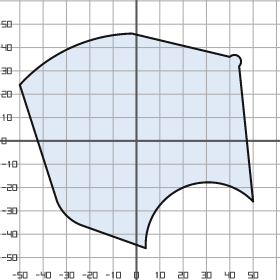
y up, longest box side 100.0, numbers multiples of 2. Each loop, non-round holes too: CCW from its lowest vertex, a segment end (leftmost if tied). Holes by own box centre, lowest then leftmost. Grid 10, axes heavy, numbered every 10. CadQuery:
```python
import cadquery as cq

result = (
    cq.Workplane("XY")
    .moveTo(4.0, -46.0)
    .threePointArc((20.0, -20.0), (50.0, -26.0))
    .lineTo(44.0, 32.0)
    .threePointArc((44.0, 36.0), (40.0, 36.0))
    .lineTo(-2.0, 46.0)
    .threePointArc((-28.0, 40.0), (-50.0, 24.0))
    .lineTo(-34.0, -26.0)
    .threePointArc((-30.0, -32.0), (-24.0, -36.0))
    .close()
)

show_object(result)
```